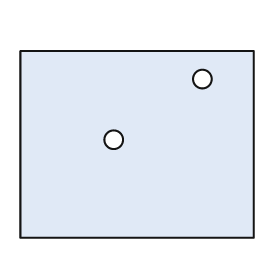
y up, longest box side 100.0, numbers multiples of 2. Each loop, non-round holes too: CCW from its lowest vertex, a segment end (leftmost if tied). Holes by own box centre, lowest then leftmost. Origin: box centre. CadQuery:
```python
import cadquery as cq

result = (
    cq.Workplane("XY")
    .moveTo(-50.0, -40.0)
    .lineTo(50.0, -40.0)
    .lineTo(50.0, 40.0)
    .lineTo(-50.0, 40.0)
    .close()
    .moveTo(-10.0, 2.0)
    .circle(4.0)
    .moveTo(28.0, 28.0)
    .circle(4.0)
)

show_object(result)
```